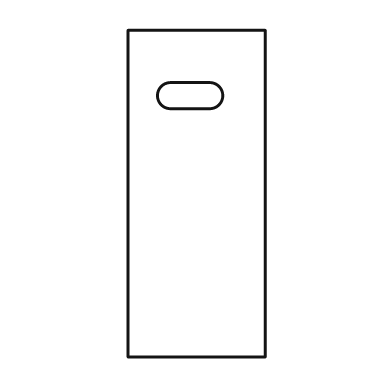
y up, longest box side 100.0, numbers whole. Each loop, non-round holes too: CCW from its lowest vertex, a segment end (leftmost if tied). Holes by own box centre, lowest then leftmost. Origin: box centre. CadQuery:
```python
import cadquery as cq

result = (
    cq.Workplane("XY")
    .moveTo(-21.0, -50.0)
    .lineTo(21.0, -50.0)
    .lineTo(21.0, 50.0)
    .lineTo(-21.0, 50.0)
    .close()
    .moveTo(-8.0, 26.0)
    .lineTo(4.0, 26.0)
    .threePointArc((8.0, 30.0), (4.0, 34.0))
    .lineTo(-8.0, 34.0)
    .threePointArc((-12.0, 30.0), (-8.0, 26.0))
    .close()
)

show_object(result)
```